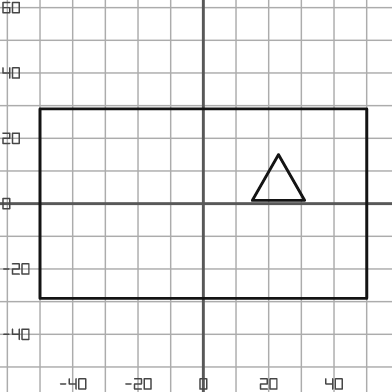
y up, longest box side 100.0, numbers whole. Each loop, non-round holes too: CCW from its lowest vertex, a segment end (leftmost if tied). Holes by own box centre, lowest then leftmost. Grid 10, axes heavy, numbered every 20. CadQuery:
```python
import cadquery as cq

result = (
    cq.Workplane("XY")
    .moveTo(-50.0, -29.0)
    .lineTo(50.0, -29.0)
    .lineTo(50.0, 29.0)
    .lineTo(-50.0, 29.0)
    .close()
    .moveTo(15.0, 1.0)
    .lineTo(31.0, 1.0)
    .lineTo(23.0, 15.0)
    .close()
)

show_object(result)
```